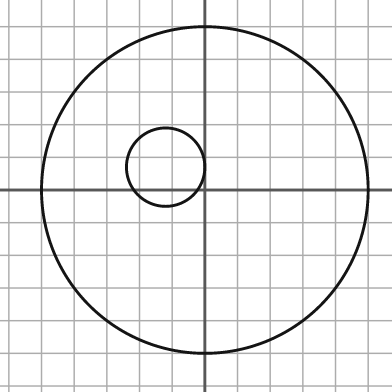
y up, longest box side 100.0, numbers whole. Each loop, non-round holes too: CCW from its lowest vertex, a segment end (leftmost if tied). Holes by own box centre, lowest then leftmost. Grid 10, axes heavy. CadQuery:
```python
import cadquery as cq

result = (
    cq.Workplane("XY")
    .moveTo(0.0, 0.0)
    .circle(50.0)
    .moveTo(-12.0, 7.0)
    .circle(12.0)
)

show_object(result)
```